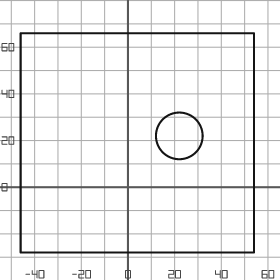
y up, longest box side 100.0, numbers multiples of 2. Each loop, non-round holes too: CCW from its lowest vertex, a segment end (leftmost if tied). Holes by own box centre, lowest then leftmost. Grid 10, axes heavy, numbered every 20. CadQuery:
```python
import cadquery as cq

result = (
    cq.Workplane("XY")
    .moveTo(-46.0, -28.0)
    .lineTo(54.0, -28.0)
    .lineTo(54.0, 66.0)
    .lineTo(-46.0, 66.0)
    .close()
    .moveTo(22.0, 22.0)
    .circle(10.0)
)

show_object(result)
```